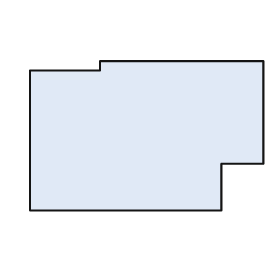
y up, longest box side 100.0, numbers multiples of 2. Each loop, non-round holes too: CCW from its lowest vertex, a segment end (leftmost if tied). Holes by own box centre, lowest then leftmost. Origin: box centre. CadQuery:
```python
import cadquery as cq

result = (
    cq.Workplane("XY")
    .moveTo(-50.0, -32.0)
    .lineTo(32.0, -32.0)
    .lineTo(32.0, -12.0)
    .lineTo(50.0, -12.0)
    .lineTo(50.0, 32.0)
    .lineTo(-20.0, 32.0)
    .lineTo(-20.0, 28.0)
    .lineTo(-50.0, 28.0)
    .close()
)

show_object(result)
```